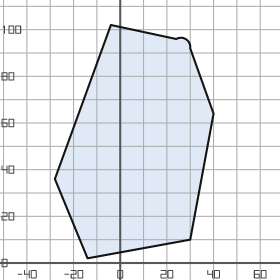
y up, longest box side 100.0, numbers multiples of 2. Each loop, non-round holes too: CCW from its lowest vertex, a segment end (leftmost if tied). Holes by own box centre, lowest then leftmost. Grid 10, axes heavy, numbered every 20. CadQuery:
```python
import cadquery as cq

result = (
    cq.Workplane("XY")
    .moveTo(-14.0, 2.0)
    .lineTo(30.0, 10.0)
    .lineTo(40.0, 64.0)
    .lineTo(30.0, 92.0)
    .threePointArc((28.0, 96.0), (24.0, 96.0))
    .lineTo(-4.0, 102.0)
    .lineTo(-28.0, 36.0)
    .close()
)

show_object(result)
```